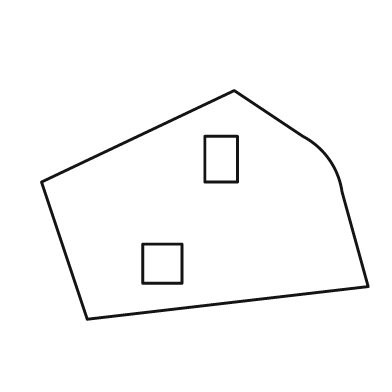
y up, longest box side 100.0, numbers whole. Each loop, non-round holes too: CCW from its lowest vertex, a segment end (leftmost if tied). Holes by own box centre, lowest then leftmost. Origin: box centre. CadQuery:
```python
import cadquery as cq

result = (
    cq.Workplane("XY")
    .moveTo(-36.0, -35.0)
    .lineTo(50.0, -25.0)
    .lineTo(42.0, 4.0)
    .threePointArc((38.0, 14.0), (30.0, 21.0))
    .lineTo(9.0, 35.0)
    .lineTo(-50.0, 7.0)
    .close()
    .moveTo(-19.0, -24.0)
    .lineTo(-7.0, -24.0)
    .lineTo(-7.0, -12.0)
    .lineTo(-19.0, -12.0)
    .close()
    .moveTo(0.0, 7.0)
    .lineTo(10.0, 7.0)
    .lineTo(10.0, 21.0)
    .lineTo(0.0, 21.0)
    .close()
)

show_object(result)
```